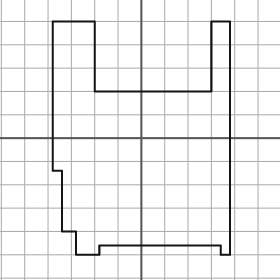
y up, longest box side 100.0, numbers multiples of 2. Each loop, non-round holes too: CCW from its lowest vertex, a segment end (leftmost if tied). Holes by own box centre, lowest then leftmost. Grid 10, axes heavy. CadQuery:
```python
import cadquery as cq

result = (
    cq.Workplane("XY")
    .moveTo(-28.0, -50.0)
    .lineTo(-18.0, -50.0)
    .lineTo(-18.0, -46.0)
    .lineTo(34.0, -46.0)
    .lineTo(34.0, -50.0)
    .lineTo(38.0, -50.0)
    .lineTo(38.0, 50.0)
    .lineTo(30.0, 50.0)
    .lineTo(30.0, 20.0)
    .lineTo(-20.0, 20.0)
    .lineTo(-20.0, 50.0)
    .lineTo(-38.0, 50.0)
    .lineTo(-38.0, -14.0)
    .lineTo(-34.0, -14.0)
    .lineTo(-34.0, -40.0)
    .lineTo(-28.0, -40.0)
    .close()
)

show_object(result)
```